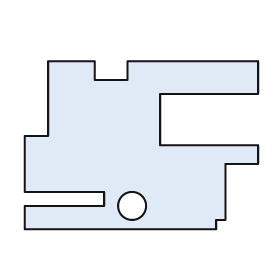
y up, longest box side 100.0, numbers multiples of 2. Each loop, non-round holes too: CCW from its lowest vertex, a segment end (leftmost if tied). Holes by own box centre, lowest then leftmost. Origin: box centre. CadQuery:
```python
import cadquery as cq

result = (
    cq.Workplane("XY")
    .moveTo(-50.0, -36.0)
    .lineTo(32.0, -36.0)
    .lineTo(32.0, -32.0)
    .lineTo(36.0, -32.0)
    .lineTo(36.0, -8.0)
    .lineTo(50.0, -8.0)
    .lineTo(50.0, 0.0)
    .lineTo(8.0, 0.0)
    .lineTo(8.0, 22.0)
    .lineTo(50.0, 22.0)
    .lineTo(50.0, 36.0)
    .lineTo(-6.0, 36.0)
    .lineTo(-6.0, 28.0)
    .lineTo(-20.0, 28.0)
    .lineTo(-20.0, 36.0)
    .lineTo(-40.0, 36.0)
    .lineTo(-40.0, 4.0)
    .lineTo(-50.0, 4.0)
    .lineTo(-50.0, -20.0)
    .lineTo(-16.0, -20.0)
    .lineTo(-16.0, -26.0)
    .lineTo(-50.0, -26.0)
    .close()
    .moveTo(-4.0, -26.0)
    .circle(6.0)
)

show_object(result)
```